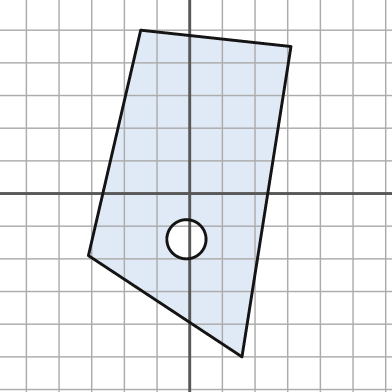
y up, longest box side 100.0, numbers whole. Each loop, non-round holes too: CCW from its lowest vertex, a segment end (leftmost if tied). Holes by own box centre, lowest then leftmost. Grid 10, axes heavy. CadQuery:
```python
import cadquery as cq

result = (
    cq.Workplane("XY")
    .moveTo(16.0, -50.0)
    .lineTo(31.0, 45.0)
    .lineTo(-15.0, 50.0)
    .lineTo(-31.0, -19.0)
    .close()
    .moveTo(-1.0, -14.0)
    .circle(6.0)
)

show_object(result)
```